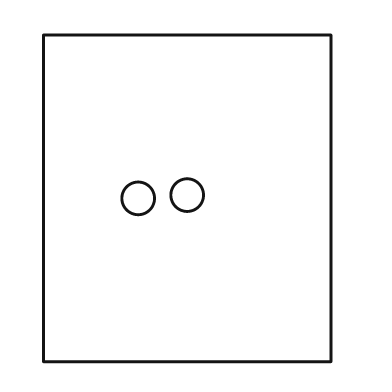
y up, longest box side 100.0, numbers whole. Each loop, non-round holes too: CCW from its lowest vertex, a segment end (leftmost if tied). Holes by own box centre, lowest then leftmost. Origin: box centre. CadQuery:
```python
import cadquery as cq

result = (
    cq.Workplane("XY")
    .moveTo(-44.0, -50.0)
    .lineTo(44.0, -50.0)
    .lineTo(44.0, 50.0)
    .lineTo(-44.0, 50.0)
    .close()
    .moveTo(-15.0, 0.0)
    .circle(5.0)
    .moveTo(0.0, 1.0)
    .circle(5.0)
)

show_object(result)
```